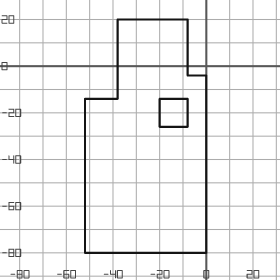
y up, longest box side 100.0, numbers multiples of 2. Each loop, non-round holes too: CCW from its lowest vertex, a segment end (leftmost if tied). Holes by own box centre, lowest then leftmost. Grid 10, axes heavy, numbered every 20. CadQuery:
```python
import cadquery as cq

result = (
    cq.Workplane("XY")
    .moveTo(-52.0, -80.0)
    .lineTo(0.0, -80.0)
    .lineTo(0.0, -4.0)
    .lineTo(-8.0, -4.0)
    .lineTo(-8.0, 20.0)
    .lineTo(-38.0, 20.0)
    .lineTo(-38.0, -14.0)
    .lineTo(-52.0, -14.0)
    .close()
    .moveTo(-20.0, -26.0)
    .lineTo(-8.0, -26.0)
    .lineTo(-8.0, -14.0)
    .lineTo(-20.0, -14.0)
    .close()
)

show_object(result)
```